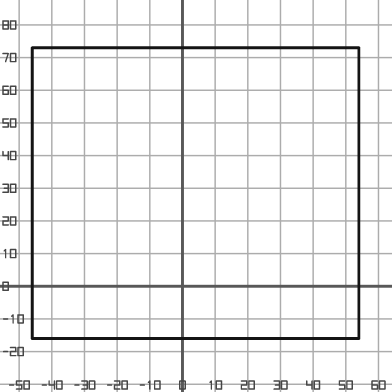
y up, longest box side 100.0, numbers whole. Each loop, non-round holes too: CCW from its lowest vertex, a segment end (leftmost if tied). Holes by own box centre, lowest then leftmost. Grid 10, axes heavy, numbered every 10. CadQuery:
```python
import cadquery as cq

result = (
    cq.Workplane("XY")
    .moveTo(-46.0, -16.0)
    .lineTo(54.0, -16.0)
    .lineTo(54.0, 73.0)
    .lineTo(-46.0, 73.0)
    .close()
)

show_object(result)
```